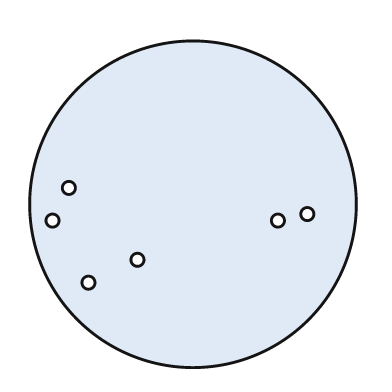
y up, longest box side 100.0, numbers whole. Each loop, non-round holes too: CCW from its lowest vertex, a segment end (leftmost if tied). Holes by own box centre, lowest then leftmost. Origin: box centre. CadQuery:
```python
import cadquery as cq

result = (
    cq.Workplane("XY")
    .moveTo(0.0, 0.0)
    .circle(50.0)
    .moveTo(-32.0, -24.0)
    .circle(2.0)
    .moveTo(-17.0, -17.0)
    .circle(2.0)
    .moveTo(-43.0, -5.0)
    .circle(2.0)
    .moveTo(26.0, -5.0)
    .circle(2.0)
    .moveTo(35.0, -3.0)
    .circle(2.0)
    .moveTo(-38.0, 5.0)
    .circle(2.0)
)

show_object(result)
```